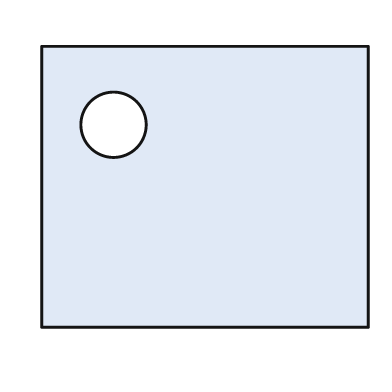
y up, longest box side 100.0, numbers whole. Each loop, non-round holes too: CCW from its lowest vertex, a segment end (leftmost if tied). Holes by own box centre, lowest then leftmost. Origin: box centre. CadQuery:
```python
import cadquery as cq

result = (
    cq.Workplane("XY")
    .moveTo(-50.0, -43.0)
    .lineTo(50.0, -43.0)
    .lineTo(50.0, 43.0)
    .lineTo(-50.0, 43.0)
    .close()
    .moveTo(-28.0, 19.0)
    .circle(10.0)
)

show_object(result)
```